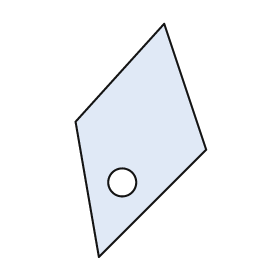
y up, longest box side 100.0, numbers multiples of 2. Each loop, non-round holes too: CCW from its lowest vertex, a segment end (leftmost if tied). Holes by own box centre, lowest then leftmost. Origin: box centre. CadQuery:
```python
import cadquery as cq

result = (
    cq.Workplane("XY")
    .moveTo(-18.0, -50.0)
    .lineTo(28.0, -4.0)
    .lineTo(10.0, 50.0)
    .lineTo(-28.0, 8.0)
    .close()
    .moveTo(-8.0, -18.0)
    .circle(6.0)
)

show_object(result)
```